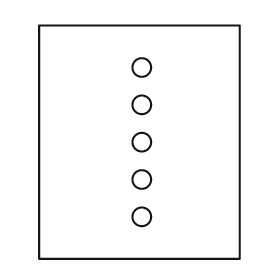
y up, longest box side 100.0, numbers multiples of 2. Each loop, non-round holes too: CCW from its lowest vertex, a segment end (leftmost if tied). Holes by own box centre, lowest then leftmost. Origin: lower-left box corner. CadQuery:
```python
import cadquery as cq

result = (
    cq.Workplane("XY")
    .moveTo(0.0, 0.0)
    .lineTo(86.0, 0.0)
    .lineTo(86.0, 100.0)
    .lineTo(0.0, 100.0)
    .close()
    .moveTo(44.0, 18.0)
    .circle(4.0)
    .moveTo(44.0, 34.0)
    .circle(4.0)
    .moveTo(44.0, 50.0)
    .circle(4.0)
    .moveTo(44.0, 66.0)
    .circle(4.0)
    .moveTo(44.0, 82.0)
    .circle(4.0)
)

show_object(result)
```